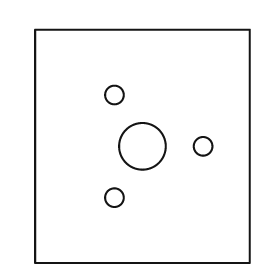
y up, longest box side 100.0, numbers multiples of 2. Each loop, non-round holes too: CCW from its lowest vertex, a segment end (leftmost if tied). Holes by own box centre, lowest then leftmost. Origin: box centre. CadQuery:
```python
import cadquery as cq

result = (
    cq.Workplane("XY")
    .moveTo(-46.0, -50.0)
    .lineTo(46.0, -50.0)
    .lineTo(46.0, 50.0)
    .lineTo(-46.0, 50.0)
    .close()
    .moveTo(-12.0, -22.0)
    .circle(4.0)
    .moveTo(0.0, 0.0)
    .circle(10.0)
    .moveTo(26.0, 0.0)
    .circle(4.0)
    .moveTo(-12.0, 22.0)
    .circle(4.0)
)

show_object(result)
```